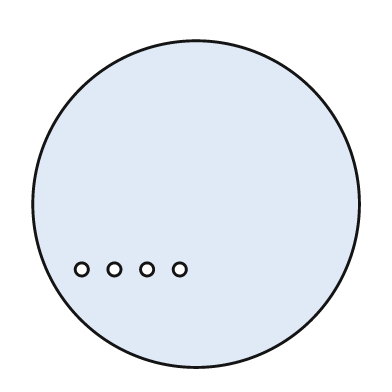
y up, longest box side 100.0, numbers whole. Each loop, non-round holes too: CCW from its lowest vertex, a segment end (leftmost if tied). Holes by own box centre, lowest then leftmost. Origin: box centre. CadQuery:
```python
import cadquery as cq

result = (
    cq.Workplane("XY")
    .moveTo(0.0, 0.0)
    .circle(50.0)
    .moveTo(-35.0, -20.0)
    .circle(2.0)
    .moveTo(-25.0, -20.0)
    .circle(2.0)
    .moveTo(-15.0, -20.0)
    .circle(2.0)
    .moveTo(-5.0, -20.0)
    .circle(2.0)
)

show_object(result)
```